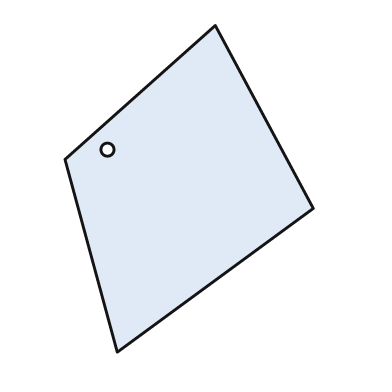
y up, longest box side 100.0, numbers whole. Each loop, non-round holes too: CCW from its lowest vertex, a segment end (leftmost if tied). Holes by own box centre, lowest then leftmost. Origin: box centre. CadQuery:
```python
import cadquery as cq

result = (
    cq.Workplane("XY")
    .moveTo(-22.0, -50.0)
    .lineTo(38.0, -6.0)
    .lineTo(8.0, 50.0)
    .lineTo(-38.0, 9.0)
    .close()
    .moveTo(-25.0, 12.0)
    .circle(2.0)
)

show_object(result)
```